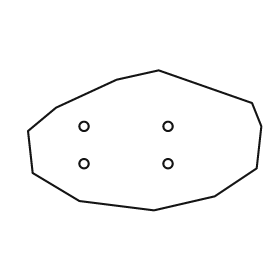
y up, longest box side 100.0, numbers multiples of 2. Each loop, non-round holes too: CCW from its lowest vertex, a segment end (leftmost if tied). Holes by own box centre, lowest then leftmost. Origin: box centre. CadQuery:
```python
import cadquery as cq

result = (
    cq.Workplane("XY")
    .moveTo(4.0, -30.0)
    .lineTo(30.0, -24.0)
    .lineTo(48.0, -12.0)
    .lineTo(50.0, 6.0)
    .lineTo(46.0, 16.0)
    .lineTo(6.0, 30.0)
    .lineTo(-12.0, 26.0)
    .lineTo(-38.0, 14.0)
    .lineTo(-50.0, 4.0)
    .lineTo(-48.0, -14.0)
    .lineTo(-28.0, -26.0)
    .close()
    .moveTo(-26.0, -10.0)
    .circle(2.0)
    .moveTo(10.0, -10.0)
    .circle(2.0)
    .moveTo(-26.0, 6.0)
    .circle(2.0)
    .moveTo(10.0, 6.0)
    .circle(2.0)
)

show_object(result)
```